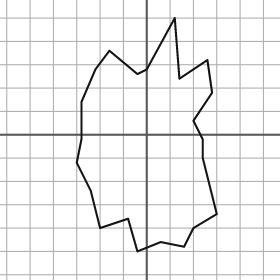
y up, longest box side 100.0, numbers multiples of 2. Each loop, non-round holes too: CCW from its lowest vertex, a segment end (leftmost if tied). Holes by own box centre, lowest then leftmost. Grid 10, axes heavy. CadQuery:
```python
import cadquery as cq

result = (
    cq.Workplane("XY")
    .moveTo(-4.0, -50.0)
    .lineTo(6.0, -46.0)
    .lineTo(16.0, -48.0)
    .lineTo(20.0, -40.0)
    .lineTo(30.0, -34.0)
    .lineTo(24.0, -10.0)
    .lineTo(24.0, -2.0)
    .lineTo(20.0, 6.0)
    .lineTo(28.0, 18.0)
    .lineTo(26.0, 32.0)
    .lineTo(14.0, 24.0)
    .lineTo(12.0, 50.0)
    .lineTo(0.0, 28.0)
    .lineTo(-4.0, 26.0)
    .lineTo(-16.0, 36.0)
    .lineTo(-22.0, 28.0)
    .lineTo(-28.0, 14.0)
    .lineTo(-28.0, -2.0)
    .lineTo(-30.0, -12.0)
    .lineTo(-24.0, -24.0)
    .lineTo(-20.0, -40.0)
    .lineTo(-8.0, -36.0)
    .close()
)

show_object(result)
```